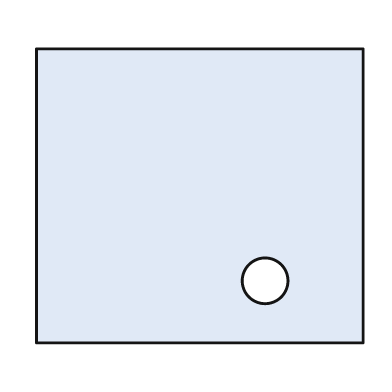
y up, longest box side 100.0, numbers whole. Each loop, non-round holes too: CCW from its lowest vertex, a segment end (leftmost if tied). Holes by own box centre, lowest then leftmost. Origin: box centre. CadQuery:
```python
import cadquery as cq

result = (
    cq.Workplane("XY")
    .moveTo(-50.0, -45.0)
    .lineTo(50.0, -45.0)
    .lineTo(50.0, 45.0)
    .lineTo(-50.0, 45.0)
    .close()
    .moveTo(20.0, -26.0)
    .circle(7.0)
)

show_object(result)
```